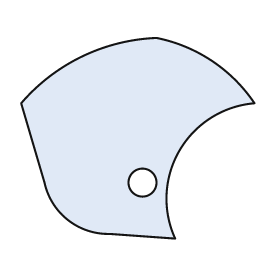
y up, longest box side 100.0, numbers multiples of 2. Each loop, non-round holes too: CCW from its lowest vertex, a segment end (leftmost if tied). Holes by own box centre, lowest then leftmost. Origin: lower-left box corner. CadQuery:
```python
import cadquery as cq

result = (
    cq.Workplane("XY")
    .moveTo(66.0, 0.0)
    .threePointArc((68.0, 38.0), (100.0, 58.0))
    .threePointArc((82.0, 76.0), (58.0, 86.0))
    .threePointArc((26.0, 78.0), (0.0, 58.0))
    .lineTo(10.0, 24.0)
    .threePointArc((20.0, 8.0), (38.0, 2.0))
    .close()
    .moveTo(52.0, 24.0)
    .circle(6.0)
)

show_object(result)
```